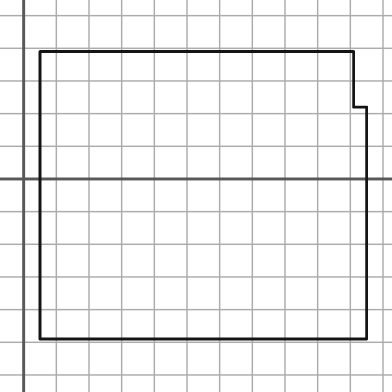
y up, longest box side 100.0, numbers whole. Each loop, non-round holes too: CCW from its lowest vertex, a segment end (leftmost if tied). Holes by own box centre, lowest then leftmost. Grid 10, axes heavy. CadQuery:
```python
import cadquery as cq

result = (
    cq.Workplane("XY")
    .moveTo(5.0, -49.0)
    .lineTo(105.0, -49.0)
    .lineTo(105.0, 22.0)
    .lineTo(101.0, 22.0)
    .lineTo(101.0, 39.0)
    .lineTo(5.0, 39.0)
    .close()
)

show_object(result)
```